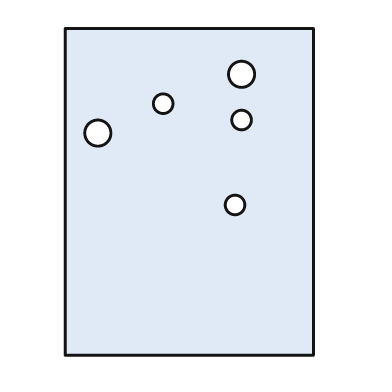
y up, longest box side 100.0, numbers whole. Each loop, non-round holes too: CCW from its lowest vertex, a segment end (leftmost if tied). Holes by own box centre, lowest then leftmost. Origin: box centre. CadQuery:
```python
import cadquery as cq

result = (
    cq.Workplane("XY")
    .moveTo(-38.0, -50.0)
    .lineTo(38.0, -50.0)
    .lineTo(38.0, 50.0)
    .lineTo(-38.0, 50.0)
    .close()
    .moveTo(14.0, -4.0)
    .circle(3.0)
    .moveTo(-28.0, 18.0)
    .circle(4.0)
    .moveTo(16.0, 22.0)
    .circle(3.0)
    .moveTo(-8.0, 27.0)
    .circle(3.0)
    .moveTo(16.0, 36.0)
    .circle(4.0)
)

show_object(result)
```